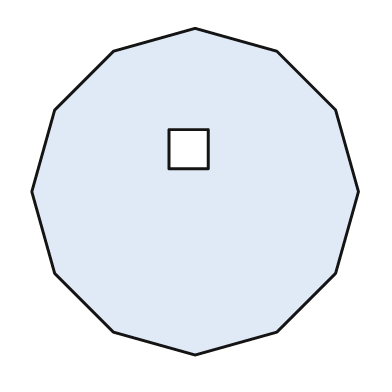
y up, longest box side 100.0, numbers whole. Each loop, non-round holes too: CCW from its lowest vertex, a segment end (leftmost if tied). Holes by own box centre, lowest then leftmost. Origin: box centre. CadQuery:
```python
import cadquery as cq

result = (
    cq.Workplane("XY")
    .moveTo(0.0, -50.0)
    .lineTo(25.0, -43.0)
    .lineTo(43.0, -25.0)
    .lineTo(50.0, 0.0)
    .lineTo(43.0, 25.0)
    .lineTo(25.0, 43.0)
    .lineTo(0.0, 50.0)
    .lineTo(-25.0, 43.0)
    .lineTo(-43.0, 25.0)
    .lineTo(-50.0, 0.0)
    .lineTo(-43.0, -25.0)
    .lineTo(-25.0, -43.0)
    .close()
    .moveTo(-8.0, 7.0)
    .lineTo(4.0, 7.0)
    .lineTo(4.0, 19.0)
    .lineTo(-8.0, 19.0)
    .close()
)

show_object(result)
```